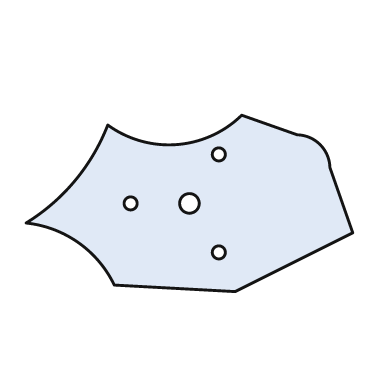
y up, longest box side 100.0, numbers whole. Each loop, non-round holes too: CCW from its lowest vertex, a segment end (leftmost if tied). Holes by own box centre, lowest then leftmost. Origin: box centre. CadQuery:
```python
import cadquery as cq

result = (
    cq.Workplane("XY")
    .moveTo(14.0, -27.0)
    .lineTo(50.0, -9.0)
    .lineTo(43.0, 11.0)
    .threePointArc((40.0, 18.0), (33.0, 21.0))
    .lineTo(16.0, 27.0)
    .threePointArc((-4.0, 18.0), (-25.0, 24.0))
    .threePointArc((-35.0, 7.0), (-50.0, -6.0))
    .threePointArc((-34.0, -12.0), (-23.0, -25.0))
    .close()
    .moveTo(9.0, -15.0)
    .circle(2.0)
    .moveTo(-18.0, 0.0)
    .circle(2.0)
    .moveTo(0.0, 0.0)
    .circle(3.0)
    .moveTo(9.0, 15.0)
    .circle(2.0)
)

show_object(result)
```